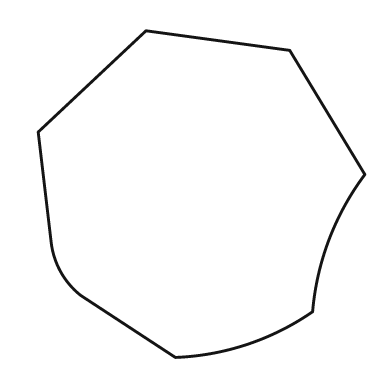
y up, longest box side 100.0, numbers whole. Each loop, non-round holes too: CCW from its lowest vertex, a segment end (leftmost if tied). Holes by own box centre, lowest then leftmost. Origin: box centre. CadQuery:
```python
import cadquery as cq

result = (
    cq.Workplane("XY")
    .moveTo(-8.0, -50.0)
    .threePointArc((14.0, -46.0), (34.0, -36.0))
    .threePointArc((39.0, -14.0), (50.0, 6.0))
    .lineTo(27.0, 44.0)
    .lineTo(-17.0, 50.0)
    .lineTo(-50.0, 19.0)
    .lineTo(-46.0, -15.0)
    .threePointArc((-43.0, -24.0), (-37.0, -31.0))
    .close()
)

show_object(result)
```